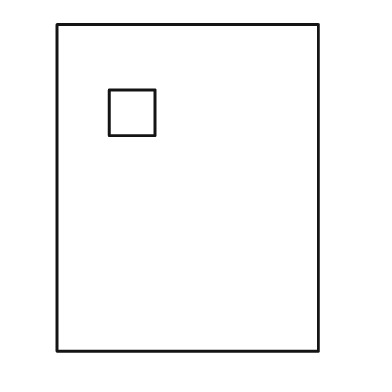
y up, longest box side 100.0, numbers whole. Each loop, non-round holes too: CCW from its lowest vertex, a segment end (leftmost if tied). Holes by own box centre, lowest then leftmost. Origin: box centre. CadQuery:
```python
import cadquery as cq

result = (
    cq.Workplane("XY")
    .moveTo(-40.0, -50.0)
    .lineTo(40.0, -50.0)
    .lineTo(40.0, 50.0)
    .lineTo(-40.0, 50.0)
    .close()
    .moveTo(-24.0, 16.0)
    .lineTo(-10.0, 16.0)
    .lineTo(-10.0, 30.0)
    .lineTo(-24.0, 30.0)
    .close()
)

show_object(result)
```